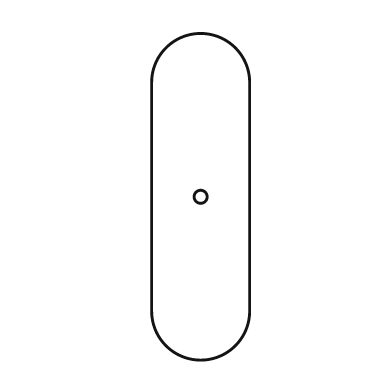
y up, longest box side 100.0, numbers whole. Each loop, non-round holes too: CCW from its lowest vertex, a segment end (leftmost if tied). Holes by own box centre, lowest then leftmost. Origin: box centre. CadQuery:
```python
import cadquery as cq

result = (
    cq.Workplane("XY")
    .moveTo(-15.0, -35.0)
    .threePointArc((0.0, -50.0), (15.0, -35.0))
    .lineTo(15.0, 35.0)
    .threePointArc((0.0, 50.0), (-15.0, 35.0))
    .close()
    .moveTo(0.0, 0.0)
    .circle(2.0)
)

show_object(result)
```